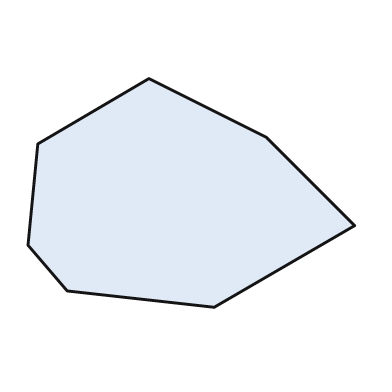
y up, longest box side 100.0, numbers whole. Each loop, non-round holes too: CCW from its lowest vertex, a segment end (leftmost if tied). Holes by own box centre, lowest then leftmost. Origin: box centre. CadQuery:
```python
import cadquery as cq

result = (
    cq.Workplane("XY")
    .moveTo(7.0, -35.0)
    .lineTo(50.0, -10.0)
    .lineTo(23.0, 17.0)
    .lineTo(-13.0, 35.0)
    .lineTo(-47.0, 15.0)
    .lineTo(-50.0, -16.0)
    .lineTo(-38.0, -30.0)
    .close()
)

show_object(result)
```